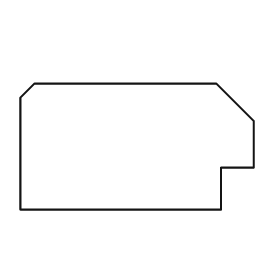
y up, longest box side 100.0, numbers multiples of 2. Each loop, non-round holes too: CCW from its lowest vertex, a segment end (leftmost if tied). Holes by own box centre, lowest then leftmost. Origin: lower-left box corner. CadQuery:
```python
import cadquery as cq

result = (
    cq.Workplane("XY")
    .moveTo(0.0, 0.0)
    .lineTo(86.0, 0.0)
    .lineTo(86.0, 18.0)
    .lineTo(100.0, 18.0)
    .lineTo(100.0, 38.0)
    .lineTo(84.0, 54.0)
    .lineTo(6.0, 54.0)
    .lineTo(0.0, 48.0)
    .close()
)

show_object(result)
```